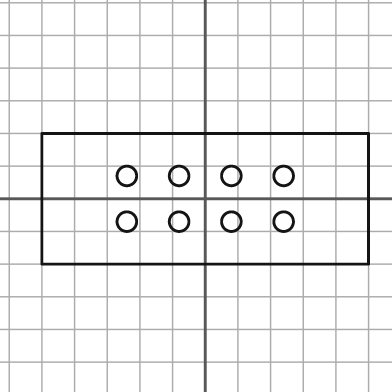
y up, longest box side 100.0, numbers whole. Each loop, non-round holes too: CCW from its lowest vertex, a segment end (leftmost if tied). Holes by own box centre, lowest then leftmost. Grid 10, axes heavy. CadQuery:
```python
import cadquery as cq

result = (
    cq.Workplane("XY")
    .moveTo(-50.0, -20.0)
    .lineTo(50.0, -20.0)
    .lineTo(50.0, 20.0)
    .lineTo(-50.0, 20.0)
    .close()
    .moveTo(-24.0, -7.0)
    .circle(3.0)
    .moveTo(-8.0, -7.0)
    .circle(3.0)
    .moveTo(8.0, -7.0)
    .circle(3.0)
    .moveTo(24.0, -7.0)
    .circle(3.0)
    .moveTo(-24.0, 7.0)
    .circle(3.0)
    .moveTo(-8.0, 7.0)
    .circle(3.0)
    .moveTo(8.0, 7.0)
    .circle(3.0)
    .moveTo(24.0, 7.0)
    .circle(3.0)
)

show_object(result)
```